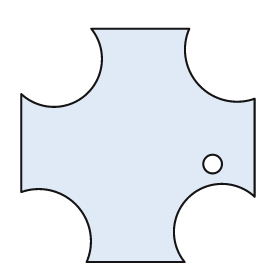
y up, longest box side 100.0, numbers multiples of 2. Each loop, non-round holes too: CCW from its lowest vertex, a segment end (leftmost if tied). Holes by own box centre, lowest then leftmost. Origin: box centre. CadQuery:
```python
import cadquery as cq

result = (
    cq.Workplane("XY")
    .moveTo(-22.0, -50.0)
    .lineTo(20.0, -50.0)
    .threePointArc((22.0, -22.0), (50.0, -22.0))
    .lineTo(50.0, 20.0)
    .threePointArc((26.0, 26.0), (22.0, 50.0))
    .lineTo(-20.0, 50.0)
    .threePointArc((-22.0, 22.0), (-50.0, 22.0))
    .lineTo(-50.0, -20.0)
    .threePointArc((-26.0, -26.0), (-22.0, -50.0))
    .close()
    .moveTo(32.0, -8.0)
    .circle(4.0)
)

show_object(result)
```